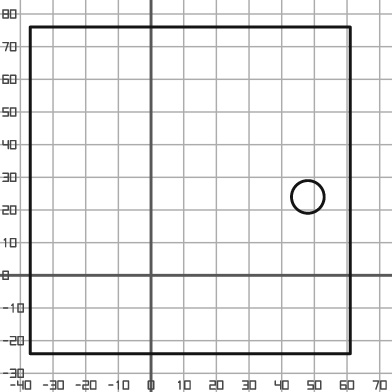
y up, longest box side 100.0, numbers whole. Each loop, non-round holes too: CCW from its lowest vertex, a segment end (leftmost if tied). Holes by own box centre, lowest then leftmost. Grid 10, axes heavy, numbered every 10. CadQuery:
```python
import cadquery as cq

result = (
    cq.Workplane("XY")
    .moveTo(-37.0, -24.0)
    .lineTo(61.0, -24.0)
    .lineTo(61.0, 76.0)
    .lineTo(-37.0, 76.0)
    .close()
    .moveTo(48.0, 24.0)
    .circle(5.0)
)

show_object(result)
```